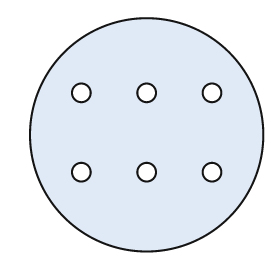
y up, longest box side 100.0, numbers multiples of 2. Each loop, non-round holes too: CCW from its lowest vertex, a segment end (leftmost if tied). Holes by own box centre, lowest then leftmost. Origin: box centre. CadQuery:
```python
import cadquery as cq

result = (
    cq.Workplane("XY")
    .moveTo(0.0, 0.0)
    .circle(50.0)
    .moveTo(-28.0, -16.0)
    .circle(4.0)
    .moveTo(0.0, -16.0)
    .circle(4.0)
    .moveTo(28.0, -16.0)
    .circle(4.0)
    .moveTo(-28.0, 18.0)
    .circle(4.0)
    .moveTo(0.0, 18.0)
    .circle(4.0)
    .moveTo(28.0, 18.0)
    .circle(4.0)
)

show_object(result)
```